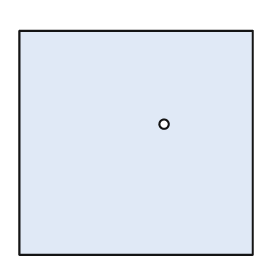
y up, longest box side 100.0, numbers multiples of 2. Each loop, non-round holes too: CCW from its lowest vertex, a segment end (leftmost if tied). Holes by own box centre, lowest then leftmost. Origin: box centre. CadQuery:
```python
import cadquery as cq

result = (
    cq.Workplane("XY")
    .moveTo(-50.0, -48.0)
    .lineTo(50.0, -48.0)
    .lineTo(50.0, 48.0)
    .lineTo(-50.0, 48.0)
    .close()
    .moveTo(12.0, 8.0)
    .circle(2.0)
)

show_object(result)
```